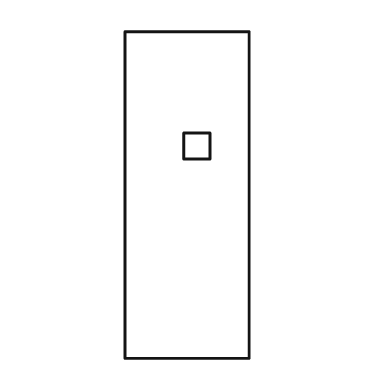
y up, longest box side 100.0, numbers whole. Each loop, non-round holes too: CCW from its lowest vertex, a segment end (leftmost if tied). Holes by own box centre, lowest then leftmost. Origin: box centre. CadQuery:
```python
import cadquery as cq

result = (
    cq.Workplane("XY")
    .moveTo(-19.0, -50.0)
    .lineTo(19.0, -50.0)
    .lineTo(19.0, 50.0)
    .lineTo(-19.0, 50.0)
    .close()
    .moveTo(-1.0, 11.0)
    .lineTo(7.0, 11.0)
    .lineTo(7.0, 19.0)
    .lineTo(-1.0, 19.0)
    .close()
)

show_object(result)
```